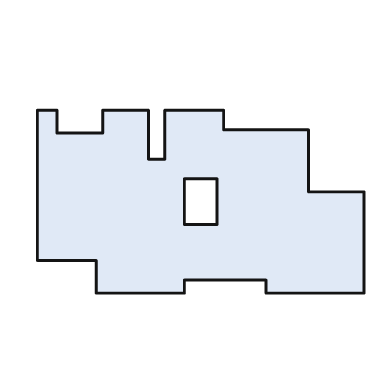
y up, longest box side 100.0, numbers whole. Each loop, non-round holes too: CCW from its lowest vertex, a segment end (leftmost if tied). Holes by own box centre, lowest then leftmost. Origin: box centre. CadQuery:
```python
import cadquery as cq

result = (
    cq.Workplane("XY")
    .moveTo(-32.0, -28.0)
    .lineTo(-5.0, -28.0)
    .lineTo(-5.0, -24.0)
    .lineTo(20.0, -24.0)
    .lineTo(20.0, -28.0)
    .lineTo(50.0, -28.0)
    .lineTo(50.0, 3.0)
    .lineTo(33.0, 3.0)
    .lineTo(33.0, 22.0)
    .lineTo(7.0, 22.0)
    .lineTo(7.0, 28.0)
    .lineTo(-11.0, 28.0)
    .lineTo(-11.0, 13.0)
    .lineTo(-16.0, 13.0)
    .lineTo(-16.0, 28.0)
    .lineTo(-30.0, 28.0)
    .lineTo(-30.0, 21.0)
    .lineTo(-44.0, 21.0)
    .lineTo(-44.0, 28.0)
    .lineTo(-50.0, 28.0)
    .lineTo(-50.0, -18.0)
    .lineTo(-32.0, -18.0)
    .close()
    .moveTo(-5.0, -7.0)
    .lineTo(5.0, -7.0)
    .lineTo(5.0, 7.0)
    .lineTo(-5.0, 7.0)
    .close()
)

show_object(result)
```